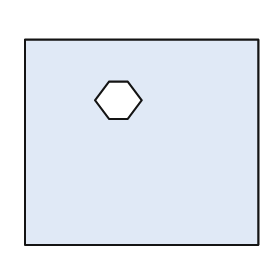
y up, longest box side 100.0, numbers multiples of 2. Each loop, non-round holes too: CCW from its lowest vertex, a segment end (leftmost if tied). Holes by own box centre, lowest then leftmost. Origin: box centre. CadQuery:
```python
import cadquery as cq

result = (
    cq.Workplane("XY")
    .moveTo(-50.0, -44.0)
    .lineTo(50.0, -44.0)
    .lineTo(50.0, 44.0)
    .lineTo(-50.0, 44.0)
    .close()
    .moveTo(-14.0, 10.0)
    .lineTo(-6.0, 10.0)
    .lineTo(0.0, 18.0)
    .lineTo(-6.0, 26.0)
    .lineTo(-14.0, 26.0)
    .lineTo(-20.0, 18.0)
    .close()
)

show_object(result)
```